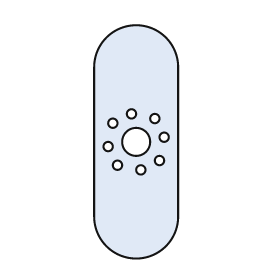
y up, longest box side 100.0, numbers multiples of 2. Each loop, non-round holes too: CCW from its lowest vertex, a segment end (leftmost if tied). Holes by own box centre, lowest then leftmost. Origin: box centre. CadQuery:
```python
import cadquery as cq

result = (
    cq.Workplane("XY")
    .moveTo(-18.0, -32.0)
    .threePointArc((0.0, -50.0), (18.0, -32.0))
    .lineTo(18.0, 32.0)
    .threePointArc((0.0, 50.0), (-18.0, 32.0))
    .close()
    .moveTo(2.0, -12.0)
    .circle(2.0)
    .moveTo(-8.0, -10.0)
    .circle(2.0)
    .moveTo(10.0, -8.0)
    .circle(2.0)
    .moveTo(-12.0, -2.0)
    .circle(2.0)
    .moveTo(0.0, 0.0)
    .circle(6.0)
    .moveTo(12.0, 2.0)
    .circle(2.0)
    .moveTo(-10.0, 8.0)
    .circle(2.0)
    .moveTo(8.0, 10.0)
    .circle(2.0)
    .moveTo(-2.0, 12.0)
    .circle(2.0)
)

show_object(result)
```